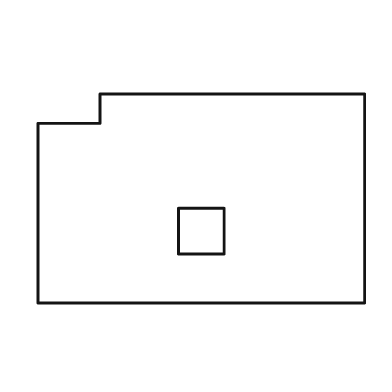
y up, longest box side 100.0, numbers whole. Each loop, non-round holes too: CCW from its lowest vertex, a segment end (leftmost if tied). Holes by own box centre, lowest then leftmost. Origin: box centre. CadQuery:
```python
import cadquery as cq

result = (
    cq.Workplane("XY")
    .moveTo(-50.0, -32.0)
    .lineTo(50.0, -32.0)
    .lineTo(50.0, 32.0)
    .lineTo(-31.0, 32.0)
    .lineTo(-31.0, 23.0)
    .lineTo(-50.0, 23.0)
    .close()
    .moveTo(-7.0, -17.0)
    .lineTo(7.0, -17.0)
    .lineTo(7.0, -3.0)
    .lineTo(-7.0, -3.0)
    .close()
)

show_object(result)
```